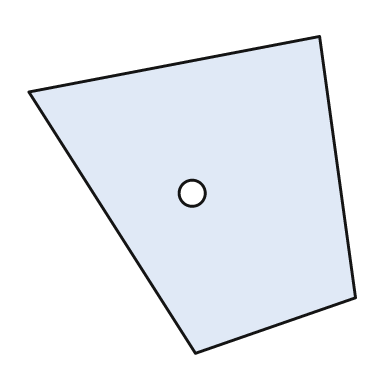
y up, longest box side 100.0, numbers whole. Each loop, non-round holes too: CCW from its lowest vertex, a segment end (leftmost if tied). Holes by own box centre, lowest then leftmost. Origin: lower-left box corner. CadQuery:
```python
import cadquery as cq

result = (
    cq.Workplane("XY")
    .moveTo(51.0, 0.0)
    .lineTo(100.0, 17.0)
    .lineTo(89.0, 97.0)
    .lineTo(0.0, 80.0)
    .close()
    .moveTo(50.0, 49.0)
    .circle(4.0)
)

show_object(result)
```